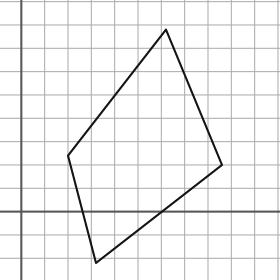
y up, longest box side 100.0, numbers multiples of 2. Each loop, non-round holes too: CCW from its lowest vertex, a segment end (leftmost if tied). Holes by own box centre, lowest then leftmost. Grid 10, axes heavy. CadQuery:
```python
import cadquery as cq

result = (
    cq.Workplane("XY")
    .moveTo(32.0, -22.0)
    .lineTo(86.0, 20.0)
    .lineTo(62.0, 78.0)
    .lineTo(20.0, 24.0)
    .close()
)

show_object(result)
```